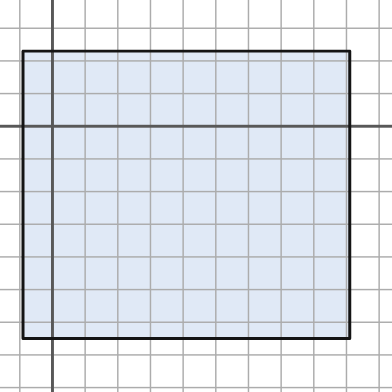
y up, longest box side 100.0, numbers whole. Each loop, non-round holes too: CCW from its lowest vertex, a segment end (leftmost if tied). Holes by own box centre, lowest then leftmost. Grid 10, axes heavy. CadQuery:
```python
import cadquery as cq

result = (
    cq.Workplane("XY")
    .moveTo(-9.0, -65.0)
    .lineTo(91.0, -65.0)
    .lineTo(91.0, 23.0)
    .lineTo(-9.0, 23.0)
    .close()
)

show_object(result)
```